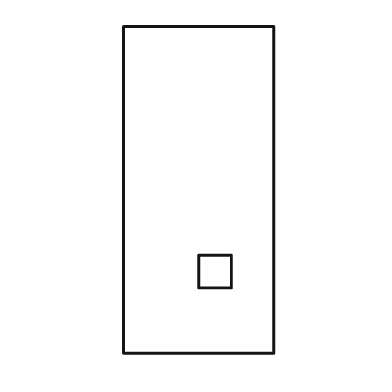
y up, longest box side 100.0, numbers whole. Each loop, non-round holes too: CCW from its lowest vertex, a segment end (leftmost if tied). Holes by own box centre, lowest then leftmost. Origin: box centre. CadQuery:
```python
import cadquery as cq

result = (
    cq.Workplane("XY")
    .moveTo(-23.0, -50.0)
    .lineTo(23.0, -50.0)
    .lineTo(23.0, 50.0)
    .lineTo(-23.0, 50.0)
    .close()
    .moveTo(0.0, -30.0)
    .lineTo(10.0, -30.0)
    .lineTo(10.0, -20.0)
    .lineTo(0.0, -20.0)
    .close()
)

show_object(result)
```